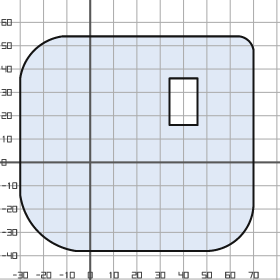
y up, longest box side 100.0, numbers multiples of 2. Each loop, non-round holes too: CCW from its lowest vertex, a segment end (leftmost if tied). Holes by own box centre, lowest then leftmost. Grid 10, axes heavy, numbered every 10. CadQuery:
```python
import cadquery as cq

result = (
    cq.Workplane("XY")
    .moveTo(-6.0, -38.0)
    .lineTo(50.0, -38.0)
    .threePointArc((64.0, -32.0), (70.0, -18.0))
    .lineTo(70.0, 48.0)
    .threePointArc((68.0, 52.0), (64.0, 54.0))
    .lineTo(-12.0, 54.0)
    .threePointArc((-24.0, 48.0), (-30.0, 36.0))
    .lineTo(-30.0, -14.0)
    .threePointArc((-22.0, -30.0), (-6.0, -38.0))
    .close()
    .moveTo(34.0, 16.0)
    .lineTo(46.0, 16.0)
    .lineTo(46.0, 36.0)
    .lineTo(34.0, 36.0)
    .close()
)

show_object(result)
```